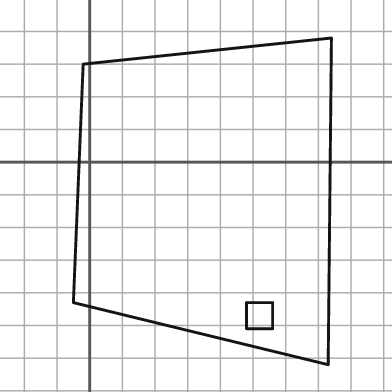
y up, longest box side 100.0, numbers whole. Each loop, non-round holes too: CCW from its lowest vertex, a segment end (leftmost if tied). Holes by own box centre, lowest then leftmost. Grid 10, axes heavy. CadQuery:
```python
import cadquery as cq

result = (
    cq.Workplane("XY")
    .moveTo(73.0, -62.0)
    .lineTo(74.0, 38.0)
    .lineTo(-2.0, 30.0)
    .lineTo(-5.0, -43.0)
    .close()
    .moveTo(48.0, -51.0)
    .lineTo(56.0, -51.0)
    .lineTo(56.0, -43.0)
    .lineTo(48.0, -43.0)
    .close()
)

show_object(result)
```